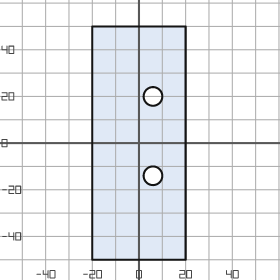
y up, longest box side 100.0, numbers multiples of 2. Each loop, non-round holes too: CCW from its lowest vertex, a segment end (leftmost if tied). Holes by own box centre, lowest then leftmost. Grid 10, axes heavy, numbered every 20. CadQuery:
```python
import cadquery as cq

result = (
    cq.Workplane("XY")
    .moveTo(-20.0, -50.0)
    .lineTo(20.0, -50.0)
    .lineTo(20.0, 50.0)
    .lineTo(-20.0, 50.0)
    .close()
    .moveTo(6.0, -14.0)
    .circle(4.0)
    .moveTo(6.0, 20.0)
    .circle(4.0)
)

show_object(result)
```